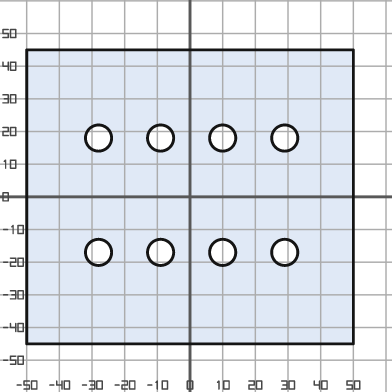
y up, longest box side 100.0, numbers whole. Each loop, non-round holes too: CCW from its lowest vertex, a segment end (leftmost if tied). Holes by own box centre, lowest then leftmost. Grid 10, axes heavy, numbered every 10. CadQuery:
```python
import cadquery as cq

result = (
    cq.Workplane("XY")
    .moveTo(-50.0, -45.0)
    .lineTo(50.0, -45.0)
    .lineTo(50.0, 45.0)
    .lineTo(-50.0, 45.0)
    .close()
    .moveTo(-28.0, -17.0)
    .circle(4.0)
    .moveTo(-9.0, -17.0)
    .circle(4.0)
    .moveTo(10.0, -17.0)
    .circle(4.0)
    .moveTo(29.0, -17.0)
    .circle(4.0)
    .moveTo(-28.0, 18.0)
    .circle(4.0)
    .moveTo(-9.0, 18.0)
    .circle(4.0)
    .moveTo(10.0, 18.0)
    .circle(4.0)
    .moveTo(29.0, 18.0)
    .circle(4.0)
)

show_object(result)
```